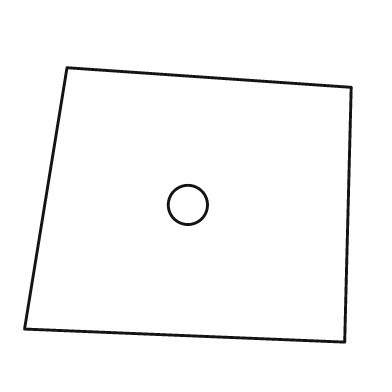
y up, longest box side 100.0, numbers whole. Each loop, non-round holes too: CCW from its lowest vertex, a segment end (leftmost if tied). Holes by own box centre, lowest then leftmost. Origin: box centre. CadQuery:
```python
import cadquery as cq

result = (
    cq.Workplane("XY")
    .moveTo(48.0, -42.0)
    .lineTo(50.0, 36.0)
    .lineTo(-37.0, 42.0)
    .lineTo(-50.0, -38.0)
    .close()
    .moveTo(0.0, 0.0)
    .circle(6.0)
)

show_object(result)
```